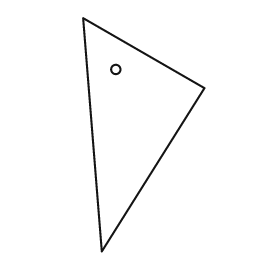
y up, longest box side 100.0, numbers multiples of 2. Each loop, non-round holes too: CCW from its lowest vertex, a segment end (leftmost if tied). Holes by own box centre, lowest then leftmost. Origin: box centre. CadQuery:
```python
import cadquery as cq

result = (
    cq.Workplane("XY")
    .moveTo(-18.0, -50.0)
    .lineTo(26.0, 20.0)
    .lineTo(-26.0, 50.0)
    .close()
    .moveTo(-12.0, 28.0)
    .circle(2.0)
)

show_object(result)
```